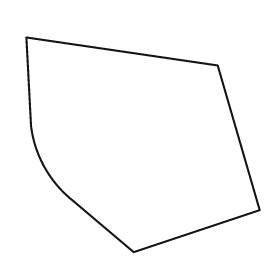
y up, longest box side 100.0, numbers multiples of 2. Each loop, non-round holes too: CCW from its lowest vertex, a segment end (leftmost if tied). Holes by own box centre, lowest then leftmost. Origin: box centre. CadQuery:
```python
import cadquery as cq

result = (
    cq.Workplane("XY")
    .moveTo(-4.0, -46.0)
    .lineTo(50.0, -28.0)
    .lineTo(32.0, 34.0)
    .lineTo(-50.0, 46.0)
    .lineTo(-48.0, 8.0)
    .threePointArc((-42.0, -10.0), (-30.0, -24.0))
    .close()
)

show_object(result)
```